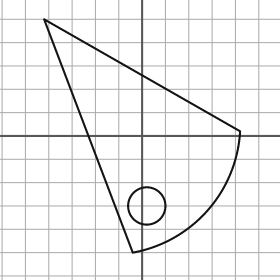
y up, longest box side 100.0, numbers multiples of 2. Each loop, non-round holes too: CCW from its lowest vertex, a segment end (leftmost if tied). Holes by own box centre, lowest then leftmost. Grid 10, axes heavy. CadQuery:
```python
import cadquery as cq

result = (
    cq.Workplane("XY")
    .moveTo(-4.0, -50.0)
    .threePointArc((28.0, -32.0), (42.0, 2.0))
    .lineTo(-42.0, 50.0)
    .close()
    .moveTo(2.0, -30.0)
    .circle(8.0)
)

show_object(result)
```